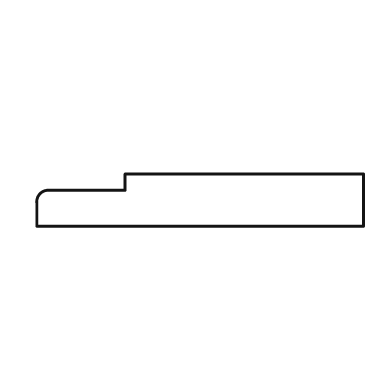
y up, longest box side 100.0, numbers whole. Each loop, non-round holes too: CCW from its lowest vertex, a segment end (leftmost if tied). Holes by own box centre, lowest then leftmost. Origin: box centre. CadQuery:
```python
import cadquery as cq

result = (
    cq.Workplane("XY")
    .moveTo(-50.0, -8.0)
    .lineTo(50.0, -8.0)
    .lineTo(50.0, 8.0)
    .lineTo(-23.0, 8.0)
    .lineTo(-23.0, 3.0)
    .lineTo(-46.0, 3.0)
    .threePointArc((-49.0, 2.0), (-50.0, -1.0))
    .close()
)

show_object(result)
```